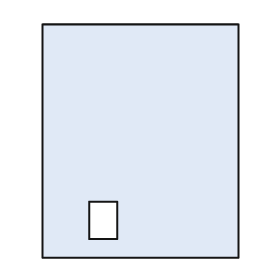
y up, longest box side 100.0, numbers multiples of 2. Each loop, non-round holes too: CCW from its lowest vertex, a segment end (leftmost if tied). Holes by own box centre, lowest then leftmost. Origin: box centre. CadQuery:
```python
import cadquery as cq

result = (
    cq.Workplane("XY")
    .moveTo(-42.0, -50.0)
    .lineTo(42.0, -50.0)
    .lineTo(42.0, 50.0)
    .lineTo(-42.0, 50.0)
    .close()
    .moveTo(-22.0, -42.0)
    .lineTo(-10.0, -42.0)
    .lineTo(-10.0, -26.0)
    .lineTo(-22.0, -26.0)
    .close()
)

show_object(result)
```